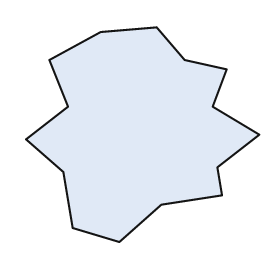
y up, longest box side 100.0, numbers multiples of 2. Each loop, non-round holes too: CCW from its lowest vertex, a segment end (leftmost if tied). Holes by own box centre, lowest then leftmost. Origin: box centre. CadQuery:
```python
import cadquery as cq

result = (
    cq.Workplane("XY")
    .moveTo(-10.0, -46.0)
    .lineTo(8.0, -30.0)
    .lineTo(34.0, -26.0)
    .lineTo(32.0, -14.0)
    .lineTo(50.0, 0.0)
    .lineTo(30.0, 12.0)
    .lineTo(36.0, 28.0)
    .lineTo(18.0, 32.0)
    .lineTo(6.0, 46.0)
    .lineTo(-18.0, 44.0)
    .lineTo(-40.0, 32.0)
    .lineTo(-32.0, 12.0)
    .lineTo(-50.0, -2.0)
    .lineTo(-34.0, -16.0)
    .lineTo(-30.0, -40.0)
    .close()
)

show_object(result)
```